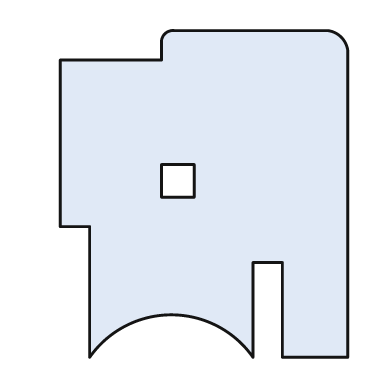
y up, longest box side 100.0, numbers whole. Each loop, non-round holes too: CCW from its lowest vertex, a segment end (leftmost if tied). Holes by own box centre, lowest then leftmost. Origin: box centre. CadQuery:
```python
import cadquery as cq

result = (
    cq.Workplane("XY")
    .moveTo(-35.0, -50.0)
    .threePointArc((-10.0, -37.0), (15.0, -50.0))
    .lineTo(15.0, -21.0)
    .lineTo(24.0, -21.0)
    .lineTo(24.0, -50.0)
    .lineTo(44.0, -50.0)
    .lineTo(44.0, 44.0)
    .threePointArc((42.0, 48.0), (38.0, 50.0))
    .lineTo(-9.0, 50.0)
    .threePointArc((-12.0, 49.0), (-13.0, 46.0))
    .lineTo(-13.0, 41.0)
    .lineTo(-44.0, 41.0)
    .lineTo(-44.0, -10.0)
    .lineTo(-35.0, -10.0)
    .close()
    .moveTo(-13.0, -1.0)
    .lineTo(-3.0, -1.0)
    .lineTo(-3.0, 9.0)
    .lineTo(-13.0, 9.0)
    .close()
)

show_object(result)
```